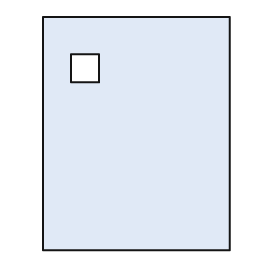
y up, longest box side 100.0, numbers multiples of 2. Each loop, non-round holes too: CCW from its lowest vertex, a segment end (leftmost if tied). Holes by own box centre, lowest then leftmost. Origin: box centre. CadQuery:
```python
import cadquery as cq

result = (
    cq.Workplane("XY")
    .moveTo(-40.0, -50.0)
    .lineTo(40.0, -50.0)
    .lineTo(40.0, 50.0)
    .lineTo(-40.0, 50.0)
    .close()
    .moveTo(-28.0, 22.0)
    .lineTo(-16.0, 22.0)
    .lineTo(-16.0, 34.0)
    .lineTo(-28.0, 34.0)
    .close()
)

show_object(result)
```